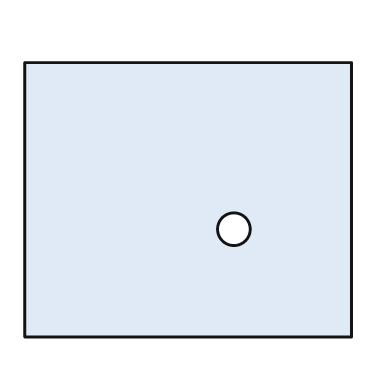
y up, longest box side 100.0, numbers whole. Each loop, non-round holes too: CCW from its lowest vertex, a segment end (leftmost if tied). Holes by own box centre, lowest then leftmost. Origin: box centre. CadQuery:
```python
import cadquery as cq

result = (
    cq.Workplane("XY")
    .moveTo(-50.0, -42.0)
    .lineTo(50.0, -42.0)
    .lineTo(50.0, 42.0)
    .lineTo(-50.0, 42.0)
    .close()
    .moveTo(14.0, -9.0)
    .circle(5.0)
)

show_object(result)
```